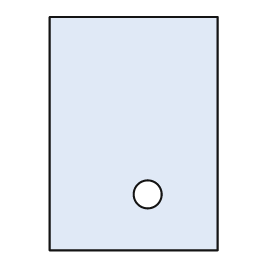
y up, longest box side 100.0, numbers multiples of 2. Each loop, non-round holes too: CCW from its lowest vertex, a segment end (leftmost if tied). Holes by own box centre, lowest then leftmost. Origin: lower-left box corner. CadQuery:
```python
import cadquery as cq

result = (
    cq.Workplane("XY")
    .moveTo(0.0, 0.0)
    .lineTo(72.0, 0.0)
    .lineTo(72.0, 100.0)
    .lineTo(0.0, 100.0)
    .close()
    .moveTo(42.0, 24.0)
    .circle(6.0)
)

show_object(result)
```